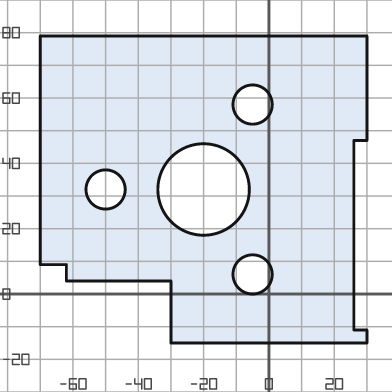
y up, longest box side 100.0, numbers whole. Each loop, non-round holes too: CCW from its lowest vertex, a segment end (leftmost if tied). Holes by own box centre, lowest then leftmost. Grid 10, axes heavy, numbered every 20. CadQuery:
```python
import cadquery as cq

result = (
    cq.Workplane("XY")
    .moveTo(-30.0, -15.0)
    .lineTo(30.0, -15.0)
    .lineTo(30.0, -11.0)
    .lineTo(26.0, -11.0)
    .lineTo(26.0, 47.0)
    .lineTo(30.0, 47.0)
    .lineTo(30.0, 79.0)
    .lineTo(-70.0, 79.0)
    .lineTo(-70.0, 9.0)
    .lineTo(-62.0, 9.0)
    .lineTo(-62.0, 4.0)
    .lineTo(-30.0, 4.0)
    .close()
    .moveTo(-5.0, 6.0)
    .circle(6.0)
    .moveTo(-50.0, 32.0)
    .circle(6.0)
    .moveTo(-20.0, 32.0)
    .circle(14.0)
    .moveTo(-5.0, 58.0)
    .circle(6.0)
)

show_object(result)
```